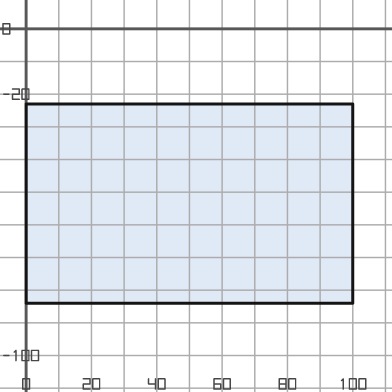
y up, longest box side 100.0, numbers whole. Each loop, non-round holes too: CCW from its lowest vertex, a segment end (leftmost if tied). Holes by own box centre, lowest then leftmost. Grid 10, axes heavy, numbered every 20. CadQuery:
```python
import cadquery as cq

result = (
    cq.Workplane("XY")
    .moveTo(0.0, -84.0)
    .lineTo(100.0, -84.0)
    .lineTo(100.0, -23.0)
    .lineTo(0.0, -23.0)
    .close()
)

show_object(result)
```